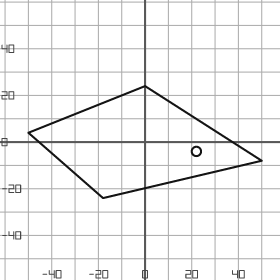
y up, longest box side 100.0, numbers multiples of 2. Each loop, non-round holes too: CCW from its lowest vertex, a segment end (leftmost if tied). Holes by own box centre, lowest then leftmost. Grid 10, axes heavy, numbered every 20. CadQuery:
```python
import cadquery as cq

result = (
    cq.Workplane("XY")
    .moveTo(-18.0, -24.0)
    .lineTo(50.0, -8.0)
    .lineTo(0.0, 24.0)
    .lineTo(-50.0, 4.0)
    .close()
    .moveTo(22.0, -4.0)
    .circle(2.0)
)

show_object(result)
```